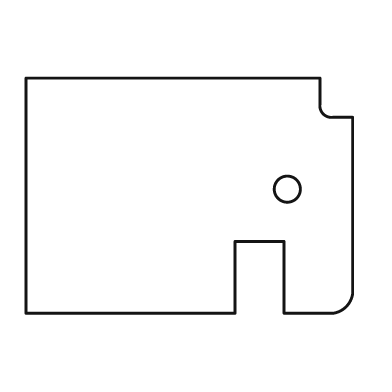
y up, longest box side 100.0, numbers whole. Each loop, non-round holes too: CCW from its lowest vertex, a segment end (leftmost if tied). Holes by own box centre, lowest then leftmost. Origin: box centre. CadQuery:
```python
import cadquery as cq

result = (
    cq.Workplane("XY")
    .moveTo(-50.0, -36.0)
    .lineTo(14.0, -36.0)
    .lineTo(14.0, -14.0)
    .lineTo(29.0, -14.0)
    .lineTo(29.0, -36.0)
    .lineTo(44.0, -36.0)
    .threePointArc((48.0, -34.0), (50.0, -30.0))
    .lineTo(50.0, 24.0)
    .lineTo(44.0, 24.0)
    .threePointArc((41.0, 25.0), (40.0, 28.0))
    .lineTo(40.0, 36.0)
    .lineTo(-50.0, 36.0)
    .close()
    .moveTo(30.0, 2.0)
    .circle(4.0)
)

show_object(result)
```